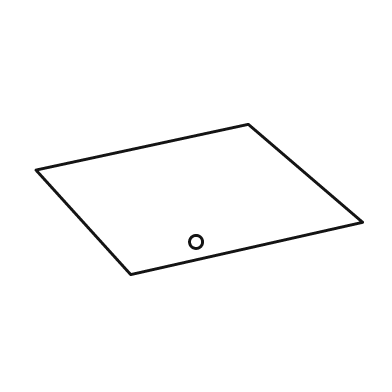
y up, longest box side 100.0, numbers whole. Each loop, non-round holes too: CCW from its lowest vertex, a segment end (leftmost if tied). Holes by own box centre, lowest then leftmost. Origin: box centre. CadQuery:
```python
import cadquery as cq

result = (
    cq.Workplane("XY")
    .moveTo(-21.0, -23.0)
    .lineTo(50.0, -7.0)
    .lineTo(15.0, 23.0)
    .lineTo(-50.0, 9.0)
    .close()
    .moveTo(-1.0, -13.0)
    .circle(2.0)
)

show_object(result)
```